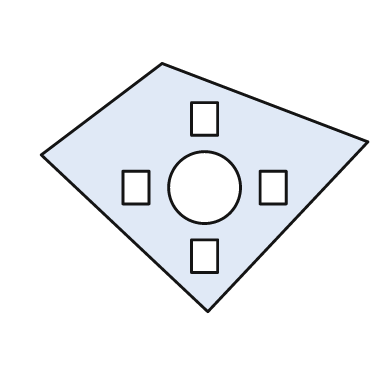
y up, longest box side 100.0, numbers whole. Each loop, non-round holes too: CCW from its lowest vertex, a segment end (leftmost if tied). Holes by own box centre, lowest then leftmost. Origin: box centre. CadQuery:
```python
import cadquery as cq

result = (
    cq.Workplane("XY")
    .moveTo(1.0, -38.0)
    .lineTo(50.0, 14.0)
    .lineTo(-13.0, 38.0)
    .lineTo(-50.0, 10.0)
    .close()
    .moveTo(-4.0, -26.0)
    .lineTo(4.0, -26.0)
    .lineTo(4.0, -16.0)
    .lineTo(-4.0, -16.0)
    .close()
    .moveTo(-25.0, -5.0)
    .lineTo(-17.0, -5.0)
    .lineTo(-17.0, 5.0)
    .lineTo(-25.0, 5.0)
    .close()
    .moveTo(0.0, 0.0)
    .circle(11.0)
    .moveTo(17.0, -5.0)
    .lineTo(25.0, -5.0)
    .lineTo(25.0, 5.0)
    .lineTo(17.0, 5.0)
    .close()
    .moveTo(-4.0, 16.0)
    .lineTo(4.0, 16.0)
    .lineTo(4.0, 26.0)
    .lineTo(-4.0, 26.0)
    .close()
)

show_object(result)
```